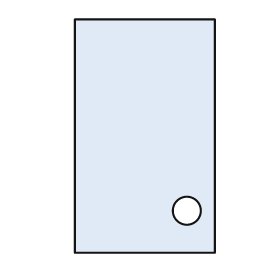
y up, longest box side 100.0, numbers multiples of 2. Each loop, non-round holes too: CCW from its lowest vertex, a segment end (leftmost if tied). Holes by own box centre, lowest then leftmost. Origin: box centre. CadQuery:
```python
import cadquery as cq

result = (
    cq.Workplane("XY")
    .moveTo(-30.0, -50.0)
    .lineTo(30.0, -50.0)
    .lineTo(30.0, 50.0)
    .lineTo(-30.0, 50.0)
    .close()
    .moveTo(18.0, -32.0)
    .circle(6.0)
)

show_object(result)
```